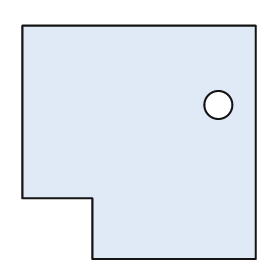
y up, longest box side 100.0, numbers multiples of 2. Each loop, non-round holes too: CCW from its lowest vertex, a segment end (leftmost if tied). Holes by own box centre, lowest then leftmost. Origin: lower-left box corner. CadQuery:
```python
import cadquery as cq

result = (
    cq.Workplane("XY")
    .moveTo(30.0, 0.0)
    .lineTo(100.0, 0.0)
    .lineTo(100.0, 100.0)
    .lineTo(0.0, 100.0)
    .lineTo(0.0, 26.0)
    .lineTo(30.0, 26.0)
    .close()
    .moveTo(84.0, 66.0)
    .circle(6.0)
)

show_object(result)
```